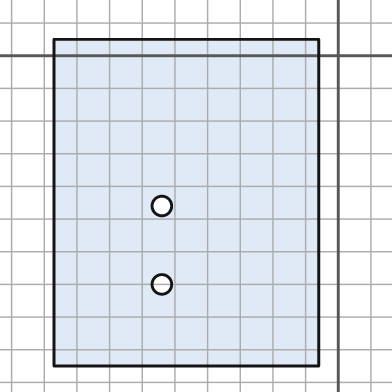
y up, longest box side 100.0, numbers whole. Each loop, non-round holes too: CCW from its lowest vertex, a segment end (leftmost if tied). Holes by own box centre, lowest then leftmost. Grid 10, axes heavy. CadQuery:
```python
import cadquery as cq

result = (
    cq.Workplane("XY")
    .moveTo(-87.0, -95.0)
    .lineTo(-6.0, -95.0)
    .lineTo(-6.0, 5.0)
    .lineTo(-87.0, 5.0)
    .close()
    .moveTo(-54.0, -70.0)
    .circle(3.0)
    .moveTo(-54.0, -46.0)
    .circle(3.0)
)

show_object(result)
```